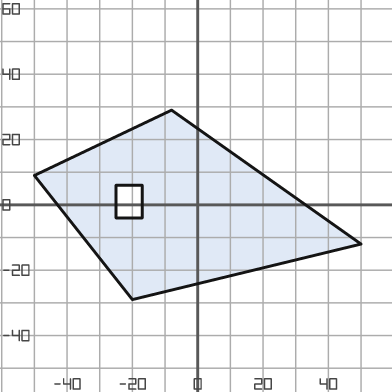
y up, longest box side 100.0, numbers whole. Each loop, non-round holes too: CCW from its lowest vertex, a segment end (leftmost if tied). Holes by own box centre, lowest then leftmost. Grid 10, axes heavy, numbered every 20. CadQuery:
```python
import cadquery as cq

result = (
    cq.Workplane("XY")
    .moveTo(-20.0, -29.0)
    .lineTo(50.0, -12.0)
    .lineTo(-8.0, 29.0)
    .lineTo(-50.0, 9.0)
    .close()
    .moveTo(-25.0, -4.0)
    .lineTo(-17.0, -4.0)
    .lineTo(-17.0, 6.0)
    .lineTo(-25.0, 6.0)
    .close()
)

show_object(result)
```